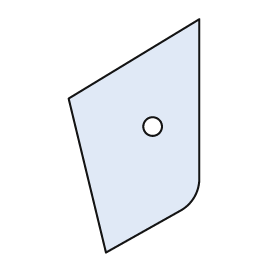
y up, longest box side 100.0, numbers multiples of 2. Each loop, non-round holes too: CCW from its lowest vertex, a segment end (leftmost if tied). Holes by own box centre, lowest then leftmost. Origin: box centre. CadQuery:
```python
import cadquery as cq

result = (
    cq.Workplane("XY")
    .moveTo(-12.0, -50.0)
    .lineTo(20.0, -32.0)
    .threePointArc((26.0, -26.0), (28.0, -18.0))
    .lineTo(28.0, 50.0)
    .lineTo(-28.0, 16.0)
    .close()
    .moveTo(8.0, 4.0)
    .circle(4.0)
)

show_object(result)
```